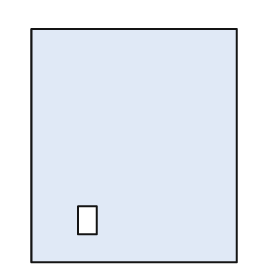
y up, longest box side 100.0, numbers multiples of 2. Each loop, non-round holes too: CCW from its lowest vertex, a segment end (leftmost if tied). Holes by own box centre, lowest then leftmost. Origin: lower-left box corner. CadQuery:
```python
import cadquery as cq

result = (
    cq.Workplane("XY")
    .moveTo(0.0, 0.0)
    .lineTo(88.0, 0.0)
    .lineTo(88.0, 100.0)
    .lineTo(0.0, 100.0)
    .close()
    .moveTo(20.0, 12.0)
    .lineTo(28.0, 12.0)
    .lineTo(28.0, 24.0)
    .lineTo(20.0, 24.0)
    .close()
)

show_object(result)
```